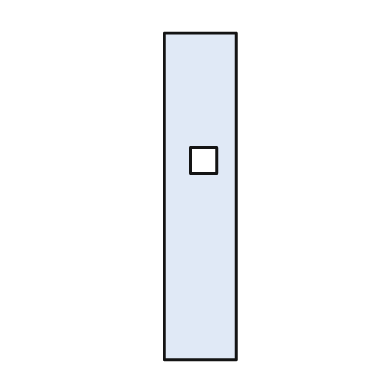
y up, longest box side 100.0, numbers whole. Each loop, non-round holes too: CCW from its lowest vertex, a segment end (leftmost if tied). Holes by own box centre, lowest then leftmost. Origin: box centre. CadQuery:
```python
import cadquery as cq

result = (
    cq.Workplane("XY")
    .moveTo(-11.0, -50.0)
    .lineTo(11.0, -50.0)
    .lineTo(11.0, 50.0)
    .lineTo(-11.0, 50.0)
    .close()
    .moveTo(-3.0, 7.0)
    .lineTo(5.0, 7.0)
    .lineTo(5.0, 15.0)
    .lineTo(-3.0, 15.0)
    .close()
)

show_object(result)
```